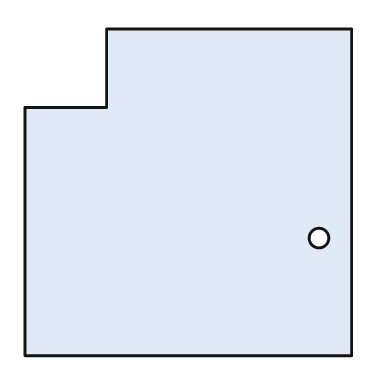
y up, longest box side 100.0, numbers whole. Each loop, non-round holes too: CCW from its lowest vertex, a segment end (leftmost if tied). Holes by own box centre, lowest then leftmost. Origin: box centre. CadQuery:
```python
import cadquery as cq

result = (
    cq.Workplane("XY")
    .moveTo(-50.0, -50.0)
    .lineTo(50.0, -50.0)
    .lineTo(50.0, 50.0)
    .lineTo(-25.0, 50.0)
    .lineTo(-25.0, 26.0)
    .lineTo(-50.0, 26.0)
    .close()
    .moveTo(40.0, -14.0)
    .circle(3.0)
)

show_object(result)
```